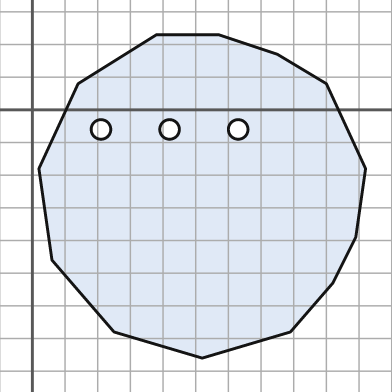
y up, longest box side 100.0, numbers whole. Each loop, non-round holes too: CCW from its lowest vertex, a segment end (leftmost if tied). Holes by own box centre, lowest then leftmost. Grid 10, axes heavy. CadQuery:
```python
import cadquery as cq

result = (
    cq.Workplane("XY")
    .moveTo(52.0, -76.0)
    .lineTo(79.0, -68.0)
    .lineTo(92.0, -53.0)
    .lineTo(99.0, -39.0)
    .lineTo(102.0, -18.0)
    .lineTo(90.0, 8.0)
    .lineTo(75.0, 17.0)
    .lineTo(57.0, 23.0)
    .lineTo(38.0, 23.0)
    .lineTo(14.0, 8.0)
    .lineTo(2.0, -18.0)
    .lineTo(6.0, -46.0)
    .lineTo(25.0, -68.0)
    .close()
    .moveTo(21.0, -6.0)
    .circle(3.0)
    .moveTo(42.0, -6.0)
    .circle(3.0)
    .moveTo(63.0, -6.0)
    .circle(3.0)
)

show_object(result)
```